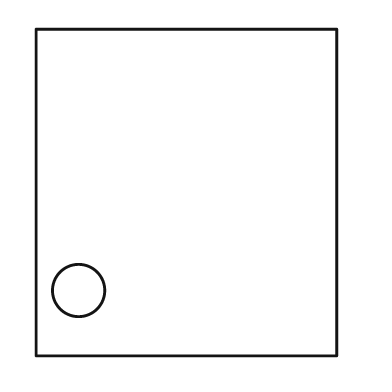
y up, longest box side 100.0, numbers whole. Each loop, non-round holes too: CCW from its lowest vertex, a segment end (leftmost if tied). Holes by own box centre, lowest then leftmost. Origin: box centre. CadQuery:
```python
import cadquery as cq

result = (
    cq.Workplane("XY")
    .moveTo(-46.0, -50.0)
    .lineTo(46.0, -50.0)
    .lineTo(46.0, 50.0)
    .lineTo(-46.0, 50.0)
    .close()
    .moveTo(-33.0, -30.0)
    .circle(8.0)
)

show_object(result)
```